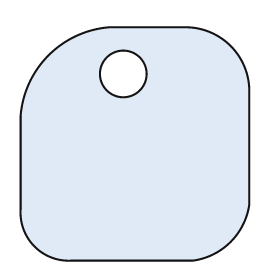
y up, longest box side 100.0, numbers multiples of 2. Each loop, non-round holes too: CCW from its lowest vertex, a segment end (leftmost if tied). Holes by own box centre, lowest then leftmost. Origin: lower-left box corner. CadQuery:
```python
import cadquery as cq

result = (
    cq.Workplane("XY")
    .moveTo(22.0, 0.0)
    .lineTo(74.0, 0.0)
    .threePointArc((90.0, 8.0), (98.0, 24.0))
    .lineTo(98.0, 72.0)
    .threePointArc((90.0, 92.0), (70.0, 100.0))
    .lineTo(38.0, 100.0)
    .threePointArc((12.0, 88.0), (0.0, 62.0))
    .lineTo(0.0, 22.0)
    .threePointArc((6.0, 6.0), (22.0, 0.0))
    .close()
    .moveTo(44.0, 80.0)
    .circle(10.0)
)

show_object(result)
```